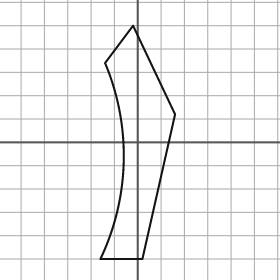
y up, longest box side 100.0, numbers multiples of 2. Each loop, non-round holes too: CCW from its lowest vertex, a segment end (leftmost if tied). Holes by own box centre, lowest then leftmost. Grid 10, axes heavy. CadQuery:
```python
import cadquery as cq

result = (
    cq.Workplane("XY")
    .moveTo(-16.0, -50.0)
    .lineTo(2.0, -50.0)
    .lineTo(16.0, 12.0)
    .lineTo(-2.0, 50.0)
    .lineTo(-14.0, 34.0)
    .threePointArc((-6.0, -8.0), (-16.0, -50.0))
    .close()
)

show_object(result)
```